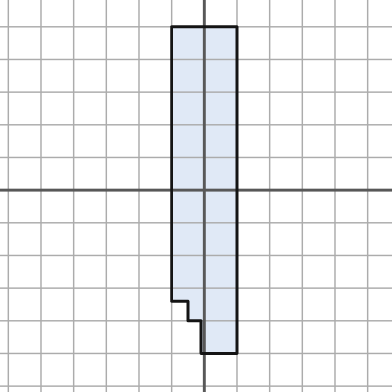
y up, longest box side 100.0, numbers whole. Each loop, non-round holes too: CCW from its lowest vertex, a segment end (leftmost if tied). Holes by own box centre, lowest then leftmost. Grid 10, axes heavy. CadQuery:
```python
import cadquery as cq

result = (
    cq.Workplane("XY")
    .moveTo(-1.0, -50.0)
    .lineTo(10.0, -50.0)
    .lineTo(10.0, 50.0)
    .lineTo(-10.0, 50.0)
    .lineTo(-10.0, -34.0)
    .lineTo(-5.0, -34.0)
    .lineTo(-5.0, -40.0)
    .lineTo(-1.0, -40.0)
    .close()
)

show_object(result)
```